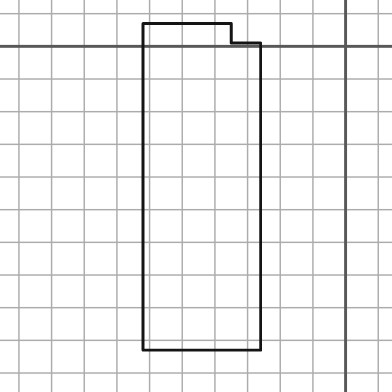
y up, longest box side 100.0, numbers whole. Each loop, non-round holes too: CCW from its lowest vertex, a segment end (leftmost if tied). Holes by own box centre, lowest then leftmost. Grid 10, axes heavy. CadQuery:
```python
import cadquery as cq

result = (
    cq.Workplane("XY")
    .moveTo(-62.0, -93.0)
    .lineTo(-26.0, -93.0)
    .lineTo(-26.0, 1.0)
    .lineTo(-35.0, 1.0)
    .lineTo(-35.0, 7.0)
    .lineTo(-62.0, 7.0)
    .close()
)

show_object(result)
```